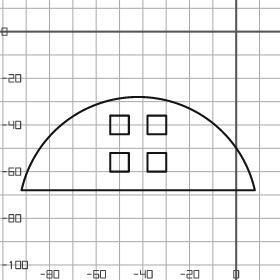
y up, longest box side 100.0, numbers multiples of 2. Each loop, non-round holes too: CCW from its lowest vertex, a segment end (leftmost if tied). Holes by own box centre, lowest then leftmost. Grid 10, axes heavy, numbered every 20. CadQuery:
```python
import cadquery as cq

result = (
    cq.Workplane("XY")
    .moveTo(-92.0, -68.0)
    .lineTo(8.0, -68.0)
    .threePointArc((-42.0, -28.0), (-92.0, -68.0))
    .close()
    .moveTo(-54.0, -60.0)
    .lineTo(-46.0, -60.0)
    .lineTo(-46.0, -52.0)
    .lineTo(-54.0, -52.0)
    .close()
    .moveTo(-38.0, -60.0)
    .lineTo(-30.0, -60.0)
    .lineTo(-30.0, -52.0)
    .lineTo(-38.0, -52.0)
    .close()
    .moveTo(-54.0, -44.0)
    .lineTo(-46.0, -44.0)
    .lineTo(-46.0, -36.0)
    .lineTo(-54.0, -36.0)
    .close()
    .moveTo(-38.0, -44.0)
    .lineTo(-30.0, -44.0)
    .lineTo(-30.0, -36.0)
    .lineTo(-38.0, -36.0)
    .close()
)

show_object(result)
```